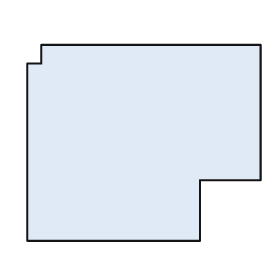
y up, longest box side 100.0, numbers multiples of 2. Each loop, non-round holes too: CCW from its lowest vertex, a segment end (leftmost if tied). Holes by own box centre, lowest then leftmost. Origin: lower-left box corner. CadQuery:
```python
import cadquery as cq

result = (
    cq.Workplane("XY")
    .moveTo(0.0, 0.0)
    .lineTo(74.0, 0.0)
    .lineTo(74.0, 26.0)
    .lineTo(100.0, 26.0)
    .lineTo(100.0, 84.0)
    .lineTo(6.0, 84.0)
    .lineTo(6.0, 76.0)
    .lineTo(0.0, 76.0)
    .close()
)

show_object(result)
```